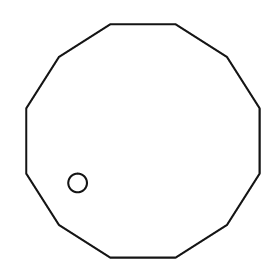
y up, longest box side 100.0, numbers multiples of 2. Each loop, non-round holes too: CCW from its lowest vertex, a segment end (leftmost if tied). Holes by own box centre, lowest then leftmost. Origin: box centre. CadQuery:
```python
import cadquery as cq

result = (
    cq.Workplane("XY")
    .moveTo(-14.0, -50.0)
    .lineTo(14.0, -50.0)
    .lineTo(36.0, -36.0)
    .lineTo(50.0, -14.0)
    .lineTo(50.0, 14.0)
    .lineTo(36.0, 36.0)
    .lineTo(14.0, 50.0)
    .lineTo(-14.0, 50.0)
    .lineTo(-36.0, 36.0)
    .lineTo(-50.0, 14.0)
    .lineTo(-50.0, -14.0)
    .lineTo(-36.0, -36.0)
    .close()
    .moveTo(-28.0, -18.0)
    .circle(4.0)
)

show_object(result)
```